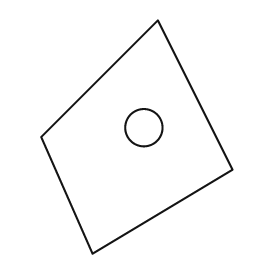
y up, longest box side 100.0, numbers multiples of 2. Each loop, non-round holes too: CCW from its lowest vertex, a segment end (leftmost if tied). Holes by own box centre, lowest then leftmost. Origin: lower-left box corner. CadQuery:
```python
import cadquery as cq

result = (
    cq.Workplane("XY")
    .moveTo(22.0, 0.0)
    .lineTo(82.0, 36.0)
    .lineTo(50.0, 100.0)
    .lineTo(0.0, 50.0)
    .close()
    .moveTo(44.0, 54.0)
    .circle(8.0)
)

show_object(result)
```